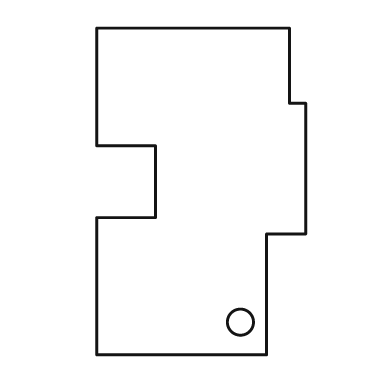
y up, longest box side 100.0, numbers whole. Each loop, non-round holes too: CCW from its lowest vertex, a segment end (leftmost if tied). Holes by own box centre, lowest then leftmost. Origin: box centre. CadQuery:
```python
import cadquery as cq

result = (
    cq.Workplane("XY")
    .moveTo(-32.0, -50.0)
    .lineTo(20.0, -50.0)
    .lineTo(20.0, -13.0)
    .lineTo(32.0, -13.0)
    .lineTo(32.0, 27.0)
    .lineTo(27.0, 27.0)
    .lineTo(27.0, 50.0)
    .lineTo(-32.0, 50.0)
    .lineTo(-32.0, 14.0)
    .lineTo(-14.0, 14.0)
    .lineTo(-14.0, -8.0)
    .lineTo(-32.0, -8.0)
    .close()
    .moveTo(12.0, -40.0)
    .circle(4.0)
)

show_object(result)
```